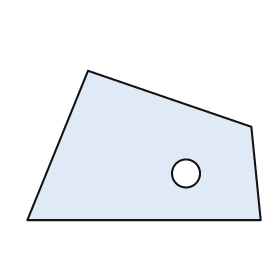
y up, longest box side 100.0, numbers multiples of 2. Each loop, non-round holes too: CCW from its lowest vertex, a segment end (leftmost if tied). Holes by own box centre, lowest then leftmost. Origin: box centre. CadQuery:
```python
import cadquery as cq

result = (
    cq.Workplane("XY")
    .moveTo(-50.0, -32.0)
    .lineTo(50.0, -32.0)
    .lineTo(46.0, 8.0)
    .lineTo(-24.0, 32.0)
    .close()
    .moveTo(18.0, -12.0)
    .circle(6.0)
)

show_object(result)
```